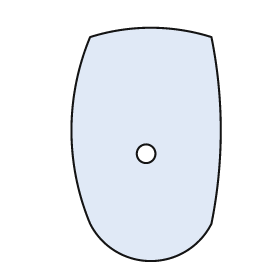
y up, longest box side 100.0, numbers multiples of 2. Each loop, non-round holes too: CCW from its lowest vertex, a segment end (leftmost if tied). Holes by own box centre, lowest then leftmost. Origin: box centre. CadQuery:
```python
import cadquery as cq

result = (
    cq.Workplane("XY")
    .moveTo(-24.0, -34.0)
    .threePointArc((2.0, -50.0), (28.0, -34.0))
    .threePointArc((32.0, 6.0), (28.0, 46.0))
    .threePointArc((2.0, 50.0), (-24.0, 46.0))
    .threePointArc((-32.0, 6.0), (-24.0, -34.0))
    .close()
    .moveTo(0.0, -4.0)
    .circle(4.0)
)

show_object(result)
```